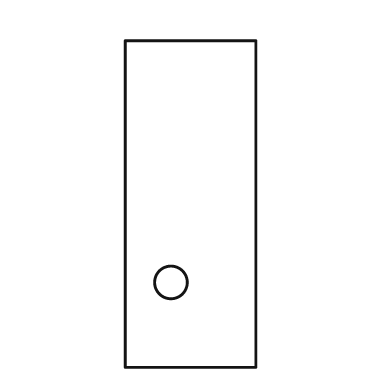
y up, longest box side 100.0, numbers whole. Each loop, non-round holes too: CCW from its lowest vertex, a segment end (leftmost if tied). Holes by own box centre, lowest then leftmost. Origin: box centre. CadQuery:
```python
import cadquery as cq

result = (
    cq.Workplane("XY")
    .moveTo(-20.0, -50.0)
    .lineTo(20.0, -50.0)
    .lineTo(20.0, 50.0)
    .lineTo(-20.0, 50.0)
    .close()
    .moveTo(-6.0, -24.0)
    .circle(5.0)
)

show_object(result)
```